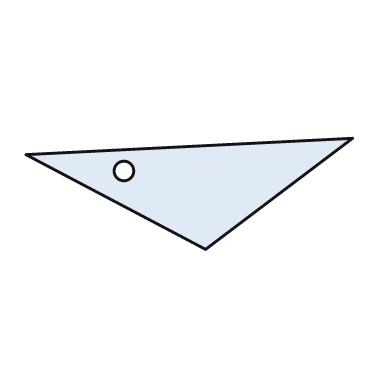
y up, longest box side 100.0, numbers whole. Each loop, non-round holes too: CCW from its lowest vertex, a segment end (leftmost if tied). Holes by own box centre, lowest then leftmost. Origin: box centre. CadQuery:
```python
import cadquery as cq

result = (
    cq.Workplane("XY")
    .moveTo(5.0, -17.0)
    .lineTo(50.0, 17.0)
    .lineTo(-50.0, 12.0)
    .close()
    .moveTo(-20.0, 7.0)
    .circle(3.0)
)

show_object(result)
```